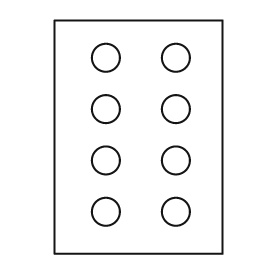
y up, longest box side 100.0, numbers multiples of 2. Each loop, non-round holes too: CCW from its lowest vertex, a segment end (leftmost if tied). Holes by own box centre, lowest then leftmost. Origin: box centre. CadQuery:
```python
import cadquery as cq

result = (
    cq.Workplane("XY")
    .moveTo(-36.0, -50.0)
    .lineTo(36.0, -50.0)
    .lineTo(36.0, 50.0)
    .lineTo(-36.0, 50.0)
    .close()
    .moveTo(-14.0, -32.0)
    .circle(6.0)
    .moveTo(16.0, -32.0)
    .circle(6.0)
    .moveTo(-14.0, -10.0)
    .circle(6.0)
    .moveTo(16.0, -10.0)
    .circle(6.0)
    .moveTo(-14.0, 12.0)
    .circle(6.0)
    .moveTo(16.0, 12.0)
    .circle(6.0)
    .moveTo(-14.0, 34.0)
    .circle(6.0)
    .moveTo(16.0, 34.0)
    .circle(6.0)
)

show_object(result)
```